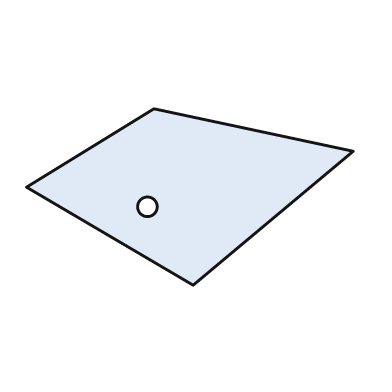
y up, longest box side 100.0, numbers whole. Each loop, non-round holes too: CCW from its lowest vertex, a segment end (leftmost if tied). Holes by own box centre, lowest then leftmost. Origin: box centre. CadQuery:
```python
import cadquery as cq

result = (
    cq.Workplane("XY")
    .moveTo(1.0, -27.0)
    .lineTo(50.0, 14.0)
    .lineTo(-11.0, 27.0)
    .lineTo(-50.0, 3.0)
    .close()
    .moveTo(-13.0, -3.0)
    .circle(3.0)
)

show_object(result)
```